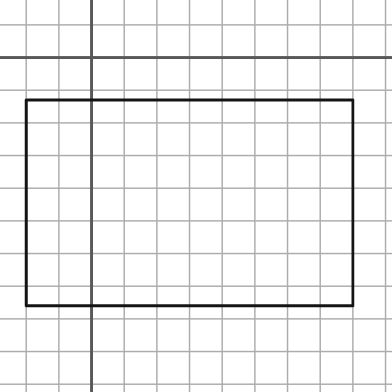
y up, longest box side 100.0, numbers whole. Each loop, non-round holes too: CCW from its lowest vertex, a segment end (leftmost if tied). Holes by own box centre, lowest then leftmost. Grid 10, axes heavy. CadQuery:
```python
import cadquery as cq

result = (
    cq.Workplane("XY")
    .moveTo(-20.0, -76.0)
    .lineTo(80.0, -76.0)
    .lineTo(80.0, -13.0)
    .lineTo(-20.0, -13.0)
    .close()
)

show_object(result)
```